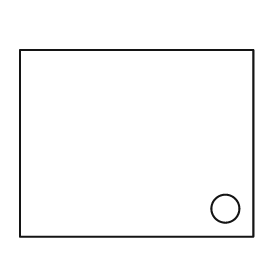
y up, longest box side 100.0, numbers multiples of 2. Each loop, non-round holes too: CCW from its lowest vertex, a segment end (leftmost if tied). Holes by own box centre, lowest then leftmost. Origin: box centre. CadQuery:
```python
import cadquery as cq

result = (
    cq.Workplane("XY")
    .moveTo(-50.0, -40.0)
    .lineTo(50.0, -40.0)
    .lineTo(50.0, 40.0)
    .lineTo(-50.0, 40.0)
    .close()
    .moveTo(38.0, -28.0)
    .circle(6.0)
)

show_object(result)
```